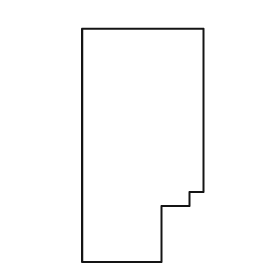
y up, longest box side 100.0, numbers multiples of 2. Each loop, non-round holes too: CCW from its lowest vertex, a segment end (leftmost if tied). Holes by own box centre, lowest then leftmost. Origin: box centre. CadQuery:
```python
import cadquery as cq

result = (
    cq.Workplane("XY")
    .moveTo(-26.0, -50.0)
    .lineTo(8.0, -50.0)
    .lineTo(8.0, -26.0)
    .lineTo(20.0, -26.0)
    .lineTo(20.0, -20.0)
    .lineTo(26.0, -20.0)
    .lineTo(26.0, 50.0)
    .lineTo(-26.0, 50.0)
    .close()
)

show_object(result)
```